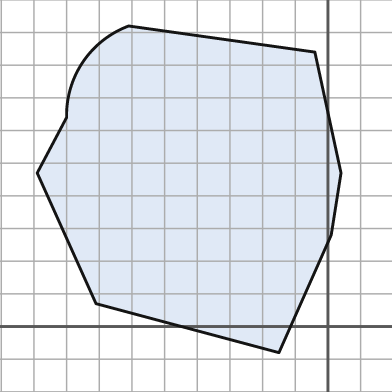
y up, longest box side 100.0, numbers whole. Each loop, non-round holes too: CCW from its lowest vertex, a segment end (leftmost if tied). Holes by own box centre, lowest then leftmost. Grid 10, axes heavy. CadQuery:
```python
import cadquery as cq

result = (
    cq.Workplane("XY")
    .moveTo(-15.0, -8.0)
    .lineTo(1.0, 28.0)
    .lineTo(4.0, 47.0)
    .lineTo(-4.0, 84.0)
    .lineTo(-61.0, 92.0)
    .threePointArc((-75.0, 81.0), (-80.0, 64.0))
    .lineTo(-89.0, 47.0)
    .lineTo(-71.0, 7.0)
    .close()
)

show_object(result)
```